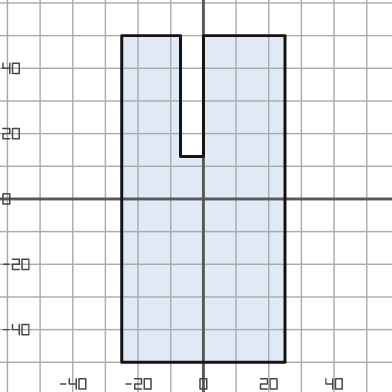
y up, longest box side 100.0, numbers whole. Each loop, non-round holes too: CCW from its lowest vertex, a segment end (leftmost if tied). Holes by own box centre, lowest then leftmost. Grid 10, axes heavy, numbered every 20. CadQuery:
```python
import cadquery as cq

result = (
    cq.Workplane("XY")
    .moveTo(-25.0, -50.0)
    .lineTo(25.0, -50.0)
    .lineTo(25.0, 50.0)
    .lineTo(0.0, 50.0)
    .lineTo(0.0, 13.0)
    .lineTo(-7.0, 13.0)
    .lineTo(-7.0, 50.0)
    .lineTo(-25.0, 50.0)
    .close()
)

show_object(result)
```